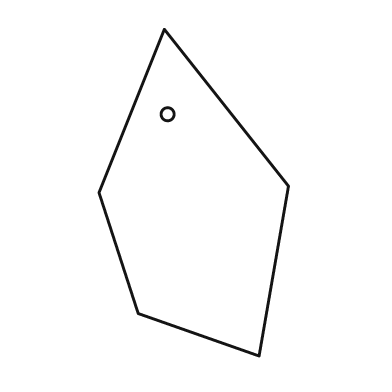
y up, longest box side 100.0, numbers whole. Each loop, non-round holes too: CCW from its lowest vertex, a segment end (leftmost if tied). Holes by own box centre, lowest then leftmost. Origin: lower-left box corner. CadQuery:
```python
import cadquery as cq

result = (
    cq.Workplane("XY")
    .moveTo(49.0, 0.0)
    .lineTo(58.0, 52.0)
    .lineTo(20.0, 100.0)
    .lineTo(0.0, 50.0)
    .lineTo(12.0, 13.0)
    .close()
    .moveTo(21.0, 74.0)
    .circle(2.0)
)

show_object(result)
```